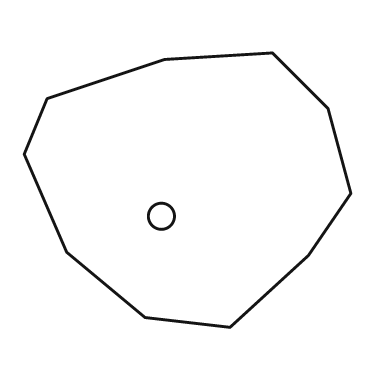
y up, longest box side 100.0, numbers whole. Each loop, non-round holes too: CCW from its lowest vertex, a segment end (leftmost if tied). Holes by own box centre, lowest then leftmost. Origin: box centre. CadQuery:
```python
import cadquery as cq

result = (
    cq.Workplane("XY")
    .moveTo(13.0, -42.0)
    .lineTo(37.0, -20.0)
    .lineTo(50.0, -1.0)
    .lineTo(43.0, 25.0)
    .lineTo(26.0, 42.0)
    .lineTo(-7.0, 40.0)
    .lineTo(-43.0, 28.0)
    .lineTo(-50.0, 11.0)
    .lineTo(-37.0, -19.0)
    .lineTo(-13.0, -39.0)
    .close()
    .moveTo(-8.0, -8.0)
    .circle(4.0)
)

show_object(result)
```